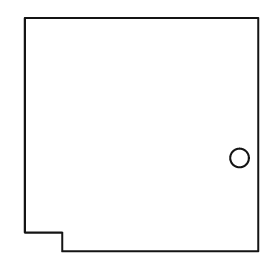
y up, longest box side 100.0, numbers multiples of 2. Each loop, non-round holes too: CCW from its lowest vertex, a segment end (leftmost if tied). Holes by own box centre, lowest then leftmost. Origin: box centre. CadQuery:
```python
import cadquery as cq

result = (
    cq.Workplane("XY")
    .moveTo(-34.0, -50.0)
    .lineTo(50.0, -50.0)
    .lineTo(50.0, 50.0)
    .lineTo(-50.0, 50.0)
    .lineTo(-50.0, -42.0)
    .lineTo(-34.0, -42.0)
    .close()
    .moveTo(42.0, -10.0)
    .circle(4.0)
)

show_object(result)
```